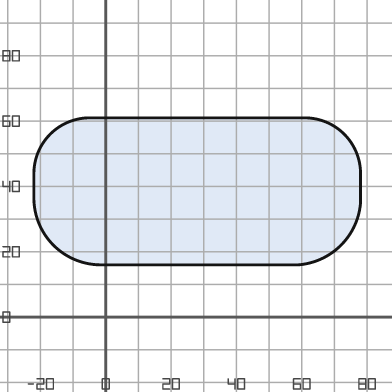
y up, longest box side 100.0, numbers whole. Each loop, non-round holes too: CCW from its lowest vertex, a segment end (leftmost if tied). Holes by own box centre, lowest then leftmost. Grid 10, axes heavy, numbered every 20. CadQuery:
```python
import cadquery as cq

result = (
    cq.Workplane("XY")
    .moveTo(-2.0, 16.0)
    .lineTo(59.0, 16.0)
    .threePointArc((72.0, 22.0), (78.0, 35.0))
    .lineTo(78.0, 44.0)
    .threePointArc((73.0, 56.0), (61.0, 61.0))
    .lineTo(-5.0, 61.0)
    .threePointArc((-17.0, 56.0), (-22.0, 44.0))
    .lineTo(-22.0, 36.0)
    .threePointArc((-16.0, 22.0), (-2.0, 16.0))
    .close()
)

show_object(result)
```